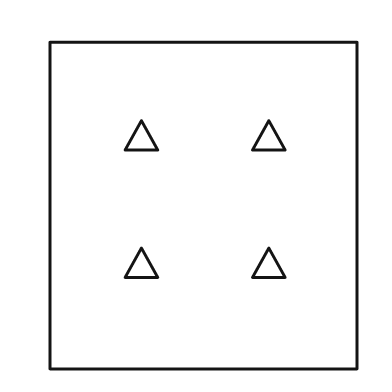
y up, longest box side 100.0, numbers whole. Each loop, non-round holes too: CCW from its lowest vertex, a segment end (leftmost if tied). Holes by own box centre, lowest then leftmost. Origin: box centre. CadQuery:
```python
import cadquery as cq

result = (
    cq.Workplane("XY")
    .moveTo(-47.0, -50.0)
    .lineTo(47.0, -50.0)
    .lineTo(47.0, 50.0)
    .lineTo(-47.0, 50.0)
    .close()
    .moveTo(-24.0, -22.0)
    .lineTo(-14.0, -22.0)
    .lineTo(-19.0, -13.0)
    .close()
    .moveTo(15.0, -22.0)
    .lineTo(25.0, -22.0)
    .lineTo(20.0, -13.0)
    .close()
    .moveTo(-24.0, 17.0)
    .lineTo(-14.0, 17.0)
    .lineTo(-19.0, 26.0)
    .close()
    .moveTo(15.0, 17.0)
    .lineTo(25.0, 17.0)
    .lineTo(20.0, 26.0)
    .close()
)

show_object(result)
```